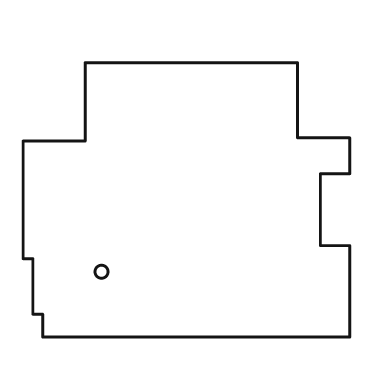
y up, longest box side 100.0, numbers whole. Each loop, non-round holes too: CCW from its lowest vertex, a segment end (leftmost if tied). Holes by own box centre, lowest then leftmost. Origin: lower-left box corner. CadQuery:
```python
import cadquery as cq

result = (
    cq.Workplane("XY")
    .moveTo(6.0, 0.0)
    .lineTo(100.0, 0.0)
    .lineTo(100.0, 28.0)
    .lineTo(91.0, 28.0)
    .lineTo(91.0, 50.0)
    .lineTo(100.0, 50.0)
    .lineTo(100.0, 61.0)
    .lineTo(84.0, 61.0)
    .lineTo(84.0, 84.0)
    .lineTo(19.0, 84.0)
    .lineTo(19.0, 60.0)
    .lineTo(0.0, 60.0)
    .lineTo(0.0, 24.0)
    .lineTo(3.0, 24.0)
    .lineTo(3.0, 7.0)
    .lineTo(6.0, 7.0)
    .close()
    .moveTo(24.0, 20.0)
    .circle(2.0)
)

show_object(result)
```